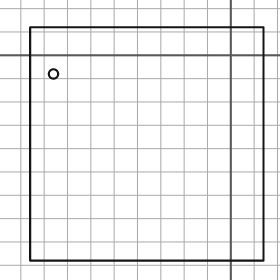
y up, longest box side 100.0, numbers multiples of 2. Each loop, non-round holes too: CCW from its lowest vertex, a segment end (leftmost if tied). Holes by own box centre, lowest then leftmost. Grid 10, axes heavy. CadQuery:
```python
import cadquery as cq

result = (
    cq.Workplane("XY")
    .moveTo(-86.0, -88.0)
    .lineTo(14.0, -88.0)
    .lineTo(14.0, 12.0)
    .lineTo(-86.0, 12.0)
    .close()
    .moveTo(-76.0, -8.0)
    .circle(2.0)
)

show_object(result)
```